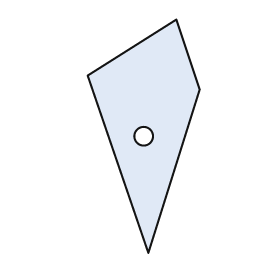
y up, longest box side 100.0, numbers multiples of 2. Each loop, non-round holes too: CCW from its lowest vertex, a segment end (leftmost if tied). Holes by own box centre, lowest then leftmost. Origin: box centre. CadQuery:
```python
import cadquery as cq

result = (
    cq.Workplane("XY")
    .moveTo(2.0, -50.0)
    .lineTo(24.0, 20.0)
    .lineTo(14.0, 50.0)
    .lineTo(-24.0, 26.0)
    .close()
    .moveTo(0.0, 0.0)
    .circle(4.0)
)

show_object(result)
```